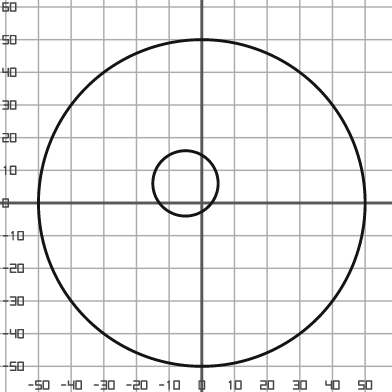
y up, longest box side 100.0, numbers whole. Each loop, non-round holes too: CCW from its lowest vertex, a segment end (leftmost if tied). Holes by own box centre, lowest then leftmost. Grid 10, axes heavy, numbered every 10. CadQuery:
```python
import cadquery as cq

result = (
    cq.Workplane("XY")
    .moveTo(0.0, 0.0)
    .circle(50.0)
    .moveTo(-5.0, 6.0)
    .circle(10.0)
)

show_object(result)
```